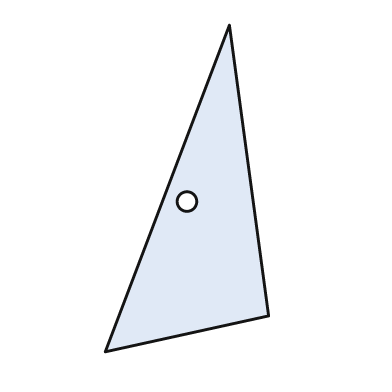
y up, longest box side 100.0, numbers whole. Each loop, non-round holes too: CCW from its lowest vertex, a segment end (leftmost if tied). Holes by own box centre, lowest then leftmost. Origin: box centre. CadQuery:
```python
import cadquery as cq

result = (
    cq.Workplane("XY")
    .moveTo(-25.0, -50.0)
    .lineTo(25.0, -39.0)
    .lineTo(13.0, 50.0)
    .close()
    .moveTo(0.0, -4.0)
    .circle(3.0)
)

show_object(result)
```